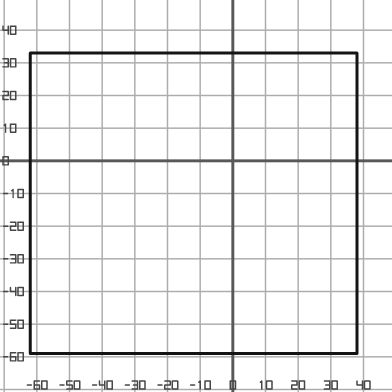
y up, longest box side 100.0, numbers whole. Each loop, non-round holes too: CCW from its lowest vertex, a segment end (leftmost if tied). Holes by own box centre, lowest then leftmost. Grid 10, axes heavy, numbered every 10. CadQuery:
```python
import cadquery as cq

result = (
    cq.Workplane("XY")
    .moveTo(-62.0, -59.0)
    .lineTo(38.0, -59.0)
    .lineTo(38.0, 33.0)
    .lineTo(-62.0, 33.0)
    .close()
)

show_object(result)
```